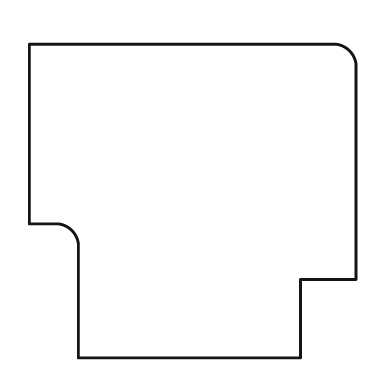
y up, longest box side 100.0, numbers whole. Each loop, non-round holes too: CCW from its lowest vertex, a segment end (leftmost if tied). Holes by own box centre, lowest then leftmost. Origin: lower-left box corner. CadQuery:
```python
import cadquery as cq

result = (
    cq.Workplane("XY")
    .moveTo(15.0, 0.0)
    .lineTo(83.0, 0.0)
    .lineTo(83.0, 24.0)
    .lineTo(100.0, 24.0)
    .lineTo(100.0, 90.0)
    .threePointArc((98.0, 94.0), (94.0, 96.0))
    .lineTo(0.0, 96.0)
    .lineTo(0.0, 41.0)
    .lineTo(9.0, 41.0)
    .threePointArc((13.0, 39.0), (15.0, 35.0))
    .close()
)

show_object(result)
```